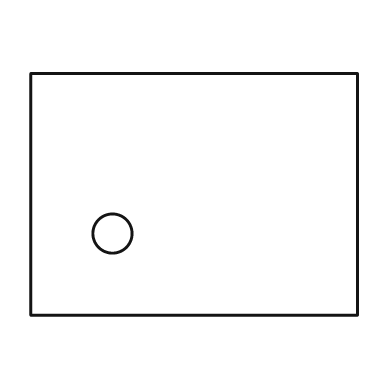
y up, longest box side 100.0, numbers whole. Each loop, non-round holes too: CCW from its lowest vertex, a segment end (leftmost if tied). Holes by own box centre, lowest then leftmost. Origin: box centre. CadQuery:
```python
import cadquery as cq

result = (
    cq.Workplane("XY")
    .moveTo(-50.0, -37.0)
    .lineTo(50.0, -37.0)
    .lineTo(50.0, 37.0)
    .lineTo(-50.0, 37.0)
    .close()
    .moveTo(-25.0, -12.0)
    .circle(6.0)
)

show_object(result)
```